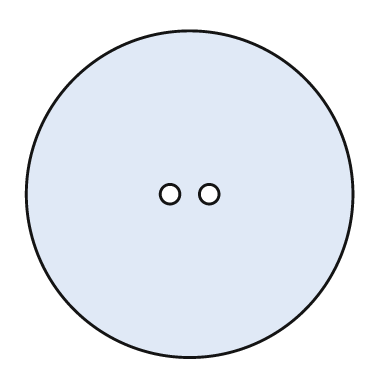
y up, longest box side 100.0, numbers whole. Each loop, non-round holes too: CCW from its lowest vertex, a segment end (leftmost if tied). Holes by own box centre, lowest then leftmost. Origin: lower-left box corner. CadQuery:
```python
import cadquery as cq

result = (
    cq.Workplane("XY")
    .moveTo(50.0, 50.0)
    .circle(50.0)
    .moveTo(44.0, 50.0)
    .circle(3.0)
    .moveTo(56.0, 50.0)
    .circle(3.0)
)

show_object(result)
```